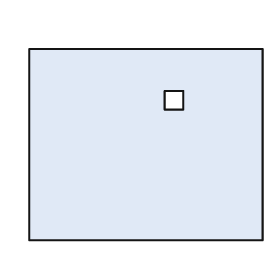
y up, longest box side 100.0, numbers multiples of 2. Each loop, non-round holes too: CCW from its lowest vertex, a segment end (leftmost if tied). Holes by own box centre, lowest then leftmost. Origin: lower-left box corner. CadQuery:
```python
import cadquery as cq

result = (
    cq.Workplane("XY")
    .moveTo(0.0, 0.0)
    .lineTo(100.0, 0.0)
    .lineTo(100.0, 82.0)
    .lineTo(0.0, 82.0)
    .close()
    .moveTo(58.0, 56.0)
    .lineTo(66.0, 56.0)
    .lineTo(66.0, 64.0)
    .lineTo(58.0, 64.0)
    .close()
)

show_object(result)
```